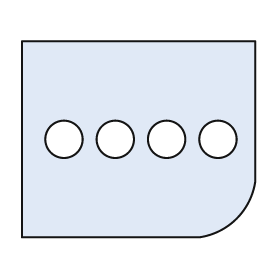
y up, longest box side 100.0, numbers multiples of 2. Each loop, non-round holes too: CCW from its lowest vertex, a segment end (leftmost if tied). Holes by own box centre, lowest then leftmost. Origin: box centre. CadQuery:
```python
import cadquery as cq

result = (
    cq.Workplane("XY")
    .moveTo(-50.0, -42.0)
    .lineTo(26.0, -42.0)
    .threePointArc((42.0, -34.0), (50.0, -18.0))
    .lineTo(50.0, 42.0)
    .lineTo(-50.0, 42.0)
    .close()
    .moveTo(-32.0, 0.0)
    .circle(8.0)
    .moveTo(-10.0, 0.0)
    .circle(8.0)
    .moveTo(12.0, 0.0)
    .circle(8.0)
    .moveTo(34.0, 0.0)
    .circle(8.0)
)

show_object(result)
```